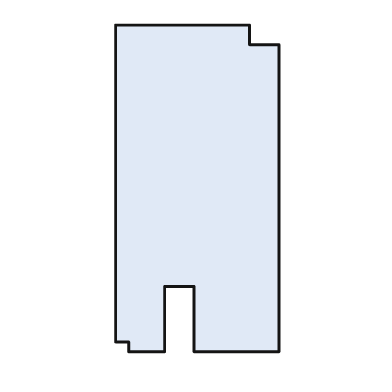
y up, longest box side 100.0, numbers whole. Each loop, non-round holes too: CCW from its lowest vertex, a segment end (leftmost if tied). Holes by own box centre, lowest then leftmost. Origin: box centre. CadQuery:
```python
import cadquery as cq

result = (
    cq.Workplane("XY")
    .moveTo(-21.0, -50.0)
    .lineTo(-10.0, -50.0)
    .lineTo(-10.0, -30.0)
    .lineTo(-1.0, -30.0)
    .lineTo(-1.0, -50.0)
    .lineTo(25.0, -50.0)
    .lineTo(25.0, 44.0)
    .lineTo(16.0, 44.0)
    .lineTo(16.0, 50.0)
    .lineTo(-25.0, 50.0)
    .lineTo(-25.0, -47.0)
    .lineTo(-21.0, -47.0)
    .close()
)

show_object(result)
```